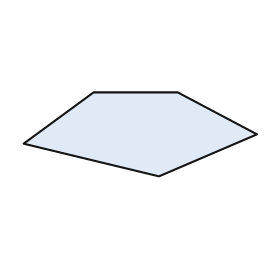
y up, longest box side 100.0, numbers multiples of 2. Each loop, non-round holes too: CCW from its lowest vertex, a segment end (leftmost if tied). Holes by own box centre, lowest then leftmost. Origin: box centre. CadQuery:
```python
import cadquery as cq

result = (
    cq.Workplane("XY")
    .moveTo(8.0, -18.0)
    .lineTo(50.0, 0.0)
    .lineTo(16.0, 18.0)
    .lineTo(-20.0, 18.0)
    .lineTo(-50.0, -4.0)
    .close()
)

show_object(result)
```